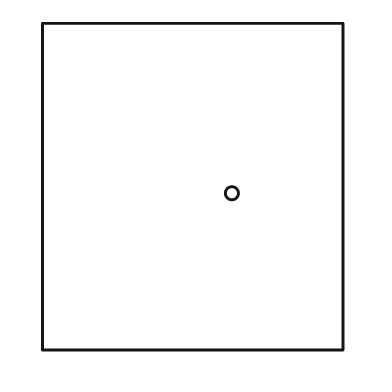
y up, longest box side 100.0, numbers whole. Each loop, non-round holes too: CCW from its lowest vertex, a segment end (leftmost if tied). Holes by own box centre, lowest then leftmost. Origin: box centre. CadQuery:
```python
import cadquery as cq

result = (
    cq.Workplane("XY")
    .moveTo(-46.0, -50.0)
    .lineTo(46.0, -50.0)
    .lineTo(46.0, 50.0)
    .lineTo(-46.0, 50.0)
    .close()
    .moveTo(12.0, -2.0)
    .circle(2.0)
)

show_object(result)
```